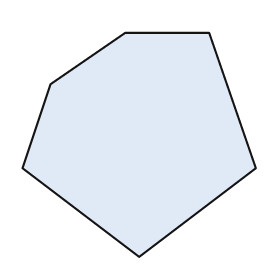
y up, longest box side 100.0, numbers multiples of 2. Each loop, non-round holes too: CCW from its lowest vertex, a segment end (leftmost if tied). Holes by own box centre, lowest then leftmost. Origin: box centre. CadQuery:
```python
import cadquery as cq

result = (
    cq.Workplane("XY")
    .moveTo(0.0, -48.0)
    .lineTo(50.0, -10.0)
    .lineTo(30.0, 48.0)
    .lineTo(-6.0, 48.0)
    .lineTo(-38.0, 26.0)
    .lineTo(-50.0, -10.0)
    .close()
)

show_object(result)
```